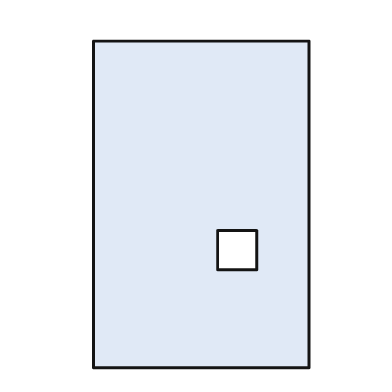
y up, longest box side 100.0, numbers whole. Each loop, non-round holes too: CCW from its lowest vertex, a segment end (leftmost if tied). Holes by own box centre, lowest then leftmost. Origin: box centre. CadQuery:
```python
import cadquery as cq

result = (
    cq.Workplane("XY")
    .moveTo(-33.0, -50.0)
    .lineTo(33.0, -50.0)
    .lineTo(33.0, 50.0)
    .lineTo(-33.0, 50.0)
    .close()
    .moveTo(5.0, -20.0)
    .lineTo(17.0, -20.0)
    .lineTo(17.0, -8.0)
    .lineTo(5.0, -8.0)
    .close()
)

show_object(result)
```